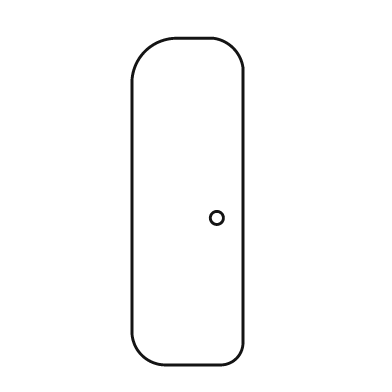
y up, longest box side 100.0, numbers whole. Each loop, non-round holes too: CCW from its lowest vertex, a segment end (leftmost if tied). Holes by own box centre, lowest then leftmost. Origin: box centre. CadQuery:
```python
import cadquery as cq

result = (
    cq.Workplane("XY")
    .moveTo(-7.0, -50.0)
    .lineTo(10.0, -50.0)
    .threePointArc((15.0, -48.0), (17.0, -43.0))
    .lineTo(17.0, 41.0)
    .threePointArc((14.0, 47.0), (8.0, 50.0))
    .lineTo(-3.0, 50.0)
    .threePointArc((-13.0, 46.0), (-17.0, 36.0))
    .lineTo(-17.0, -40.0)
    .threePointArc((-14.0, -47.0), (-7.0, -50.0))
    .close()
    .moveTo(9.0, -5.0)
    .circle(2.0)
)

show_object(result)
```